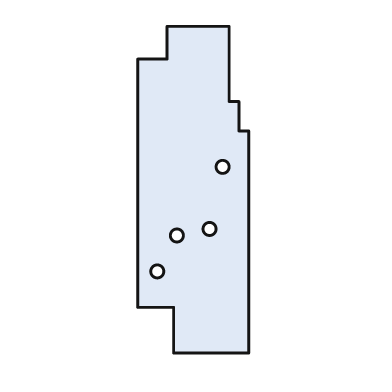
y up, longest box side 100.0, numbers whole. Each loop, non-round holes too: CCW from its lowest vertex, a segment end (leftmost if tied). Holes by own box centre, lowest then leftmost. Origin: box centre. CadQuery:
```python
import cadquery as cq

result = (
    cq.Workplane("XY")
    .moveTo(-6.0, -50.0)
    .lineTo(17.0, -50.0)
    .lineTo(17.0, 18.0)
    .lineTo(14.0, 18.0)
    .lineTo(14.0, 27.0)
    .lineTo(11.0, 27.0)
    .lineTo(11.0, 50.0)
    .lineTo(-8.0, 50.0)
    .lineTo(-8.0, 40.0)
    .lineTo(-17.0, 40.0)
    .lineTo(-17.0, -36.0)
    .lineTo(-6.0, -36.0)
    .close()
    .moveTo(-11.0, -25.0)
    .circle(2.0)
    .moveTo(-5.0, -14.0)
    .circle(2.0)
    .moveTo(5.0, -12.0)
    .circle(2.0)
    .moveTo(9.0, 7.0)
    .circle(2.0)
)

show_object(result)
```